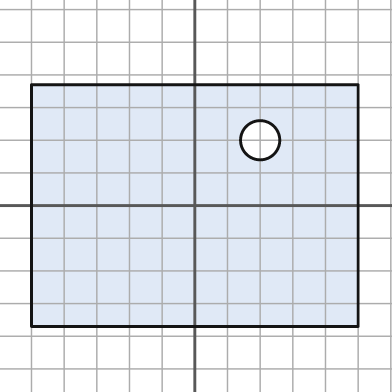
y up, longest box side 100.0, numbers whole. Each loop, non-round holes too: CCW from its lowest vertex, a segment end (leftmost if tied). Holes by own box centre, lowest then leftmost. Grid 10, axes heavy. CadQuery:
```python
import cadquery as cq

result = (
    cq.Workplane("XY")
    .moveTo(-50.0, -37.0)
    .lineTo(50.0, -37.0)
    .lineTo(50.0, 37.0)
    .lineTo(-50.0, 37.0)
    .close()
    .moveTo(20.0, 20.0)
    .circle(6.0)
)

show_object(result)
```